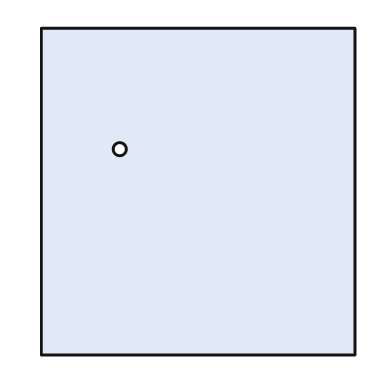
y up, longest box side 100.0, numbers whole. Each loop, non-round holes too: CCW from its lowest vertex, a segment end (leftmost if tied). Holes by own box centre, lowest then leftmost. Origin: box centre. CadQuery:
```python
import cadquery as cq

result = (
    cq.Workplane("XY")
    .moveTo(-48.0, -50.0)
    .lineTo(48.0, -50.0)
    .lineTo(48.0, 50.0)
    .lineTo(-48.0, 50.0)
    .close()
    .moveTo(-24.0, 13.0)
    .circle(2.0)
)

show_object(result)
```